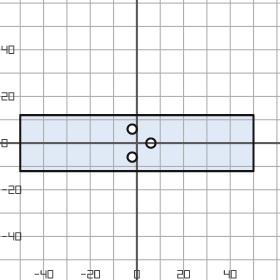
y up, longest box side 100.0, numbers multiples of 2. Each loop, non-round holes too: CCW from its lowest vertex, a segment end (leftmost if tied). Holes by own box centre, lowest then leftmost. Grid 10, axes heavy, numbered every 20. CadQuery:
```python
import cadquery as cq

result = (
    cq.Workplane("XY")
    .moveTo(-50.0, -12.0)
    .lineTo(50.0, -12.0)
    .lineTo(50.0, 12.0)
    .lineTo(-50.0, 12.0)
    .close()
    .moveTo(-2.0, -6.0)
    .circle(2.0)
    .moveTo(6.0, 0.0)
    .circle(2.0)
    .moveTo(-2.0, 6.0)
    .circle(2.0)
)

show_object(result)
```